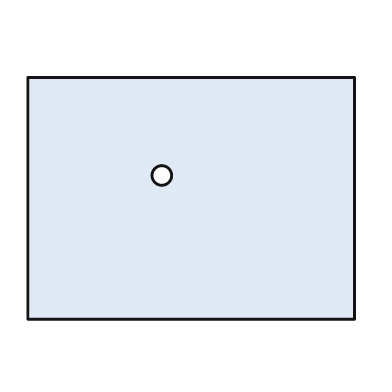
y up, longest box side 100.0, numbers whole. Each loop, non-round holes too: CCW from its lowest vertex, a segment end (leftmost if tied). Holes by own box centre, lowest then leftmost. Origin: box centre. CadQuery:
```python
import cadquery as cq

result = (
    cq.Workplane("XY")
    .moveTo(-50.0, -37.0)
    .lineTo(50.0, -37.0)
    .lineTo(50.0, 37.0)
    .lineTo(-50.0, 37.0)
    .close()
    .moveTo(-9.0, 7.0)
    .circle(3.0)
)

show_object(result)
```